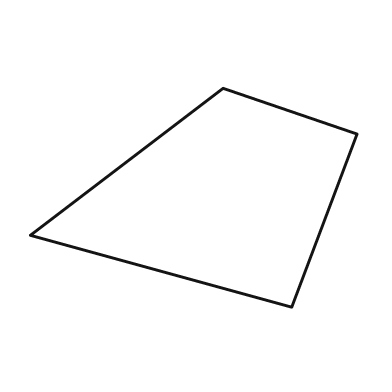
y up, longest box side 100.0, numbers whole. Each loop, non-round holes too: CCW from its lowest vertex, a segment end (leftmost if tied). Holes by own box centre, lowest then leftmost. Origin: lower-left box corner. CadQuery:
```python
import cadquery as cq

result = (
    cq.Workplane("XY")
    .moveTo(80.0, 0.0)
    .lineTo(100.0, 53.0)
    .lineTo(59.0, 67.0)
    .lineTo(0.0, 22.0)
    .close()
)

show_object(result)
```